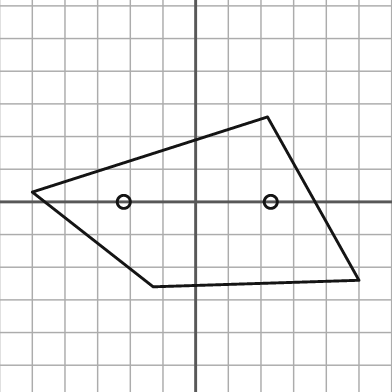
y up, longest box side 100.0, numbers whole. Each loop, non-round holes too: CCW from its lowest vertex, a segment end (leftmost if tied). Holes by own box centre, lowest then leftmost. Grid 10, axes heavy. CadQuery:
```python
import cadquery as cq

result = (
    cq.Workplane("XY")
    .moveTo(-13.0, -26.0)
    .lineTo(50.0, -24.0)
    .lineTo(22.0, 26.0)
    .lineTo(-50.0, 3.0)
    .close()
    .moveTo(-22.0, 0.0)
    .circle(2.0)
    .moveTo(23.0, 0.0)
    .circle(2.0)
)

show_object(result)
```